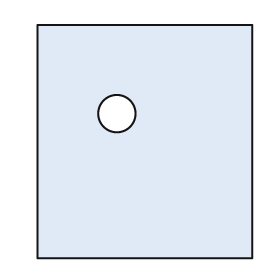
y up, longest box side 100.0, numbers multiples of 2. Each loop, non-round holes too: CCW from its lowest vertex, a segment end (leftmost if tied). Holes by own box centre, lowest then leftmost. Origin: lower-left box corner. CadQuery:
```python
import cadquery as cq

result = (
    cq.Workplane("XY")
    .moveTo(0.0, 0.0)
    .lineTo(92.0, 0.0)
    .lineTo(92.0, 100.0)
    .lineTo(0.0, 100.0)
    .close()
    .moveTo(34.0, 62.0)
    .circle(8.0)
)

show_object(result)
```